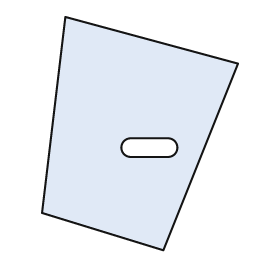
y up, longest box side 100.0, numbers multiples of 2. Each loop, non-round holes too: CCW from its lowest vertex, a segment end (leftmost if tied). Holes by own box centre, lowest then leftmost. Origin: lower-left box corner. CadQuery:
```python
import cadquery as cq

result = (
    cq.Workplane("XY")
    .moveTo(52.0, 0.0)
    .lineTo(84.0, 80.0)
    .lineTo(10.0, 100.0)
    .lineTo(0.0, 16.0)
    .close()
    .moveTo(38.0, 40.0)
    .lineTo(54.0, 40.0)
    .threePointArc((58.0, 44.0), (54.0, 48.0))
    .lineTo(38.0, 48.0)
    .threePointArc((34.0, 44.0), (38.0, 40.0))
    .close()
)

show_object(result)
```